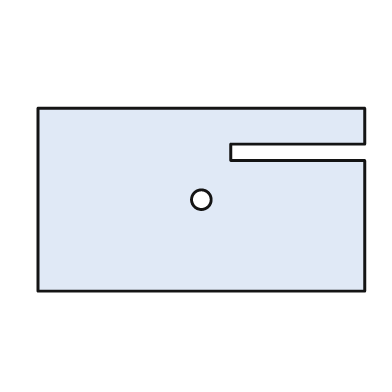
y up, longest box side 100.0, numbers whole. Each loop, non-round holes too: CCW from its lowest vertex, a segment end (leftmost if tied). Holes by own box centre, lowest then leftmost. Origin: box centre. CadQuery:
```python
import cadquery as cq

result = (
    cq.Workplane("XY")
    .moveTo(-50.0, -28.0)
    .lineTo(50.0, -28.0)
    .lineTo(50.0, 12.0)
    .lineTo(9.0, 12.0)
    .lineTo(9.0, 17.0)
    .lineTo(50.0, 17.0)
    .lineTo(50.0, 28.0)
    .lineTo(-50.0, 28.0)
    .close()
    .moveTo(0.0, 0.0)
    .circle(3.0)
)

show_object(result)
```